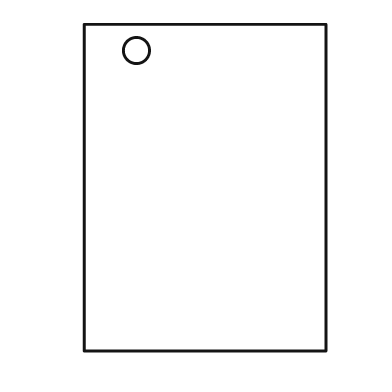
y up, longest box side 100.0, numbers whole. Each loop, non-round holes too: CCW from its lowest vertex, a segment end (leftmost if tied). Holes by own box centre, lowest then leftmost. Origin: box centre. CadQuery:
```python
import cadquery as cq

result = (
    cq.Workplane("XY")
    .moveTo(-37.0, -50.0)
    .lineTo(37.0, -50.0)
    .lineTo(37.0, 50.0)
    .lineTo(-37.0, 50.0)
    .close()
    .moveTo(-21.0, 42.0)
    .circle(4.0)
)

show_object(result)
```